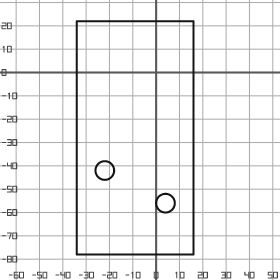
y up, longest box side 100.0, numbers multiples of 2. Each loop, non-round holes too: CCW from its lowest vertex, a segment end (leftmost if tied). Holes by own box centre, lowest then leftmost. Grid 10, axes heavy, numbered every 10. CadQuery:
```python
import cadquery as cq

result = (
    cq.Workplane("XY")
    .moveTo(-34.0, -78.0)
    .lineTo(16.0, -78.0)
    .lineTo(16.0, 22.0)
    .lineTo(-34.0, 22.0)
    .close()
    .moveTo(4.0, -56.0)
    .circle(4.0)
    .moveTo(-22.0, -42.0)
    .circle(4.0)
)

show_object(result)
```